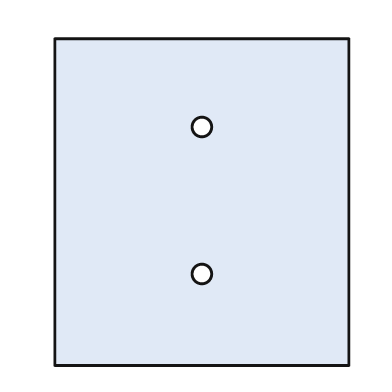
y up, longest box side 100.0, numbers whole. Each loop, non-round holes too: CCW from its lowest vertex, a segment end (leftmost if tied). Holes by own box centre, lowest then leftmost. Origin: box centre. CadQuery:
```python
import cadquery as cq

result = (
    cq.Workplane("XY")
    .moveTo(-45.0, -50.0)
    .lineTo(45.0, -50.0)
    .lineTo(45.0, 50.0)
    .lineTo(-45.0, 50.0)
    .close()
    .moveTo(0.0, -22.0)
    .circle(3.0)
    .moveTo(0.0, 23.0)
    .circle(3.0)
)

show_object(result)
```